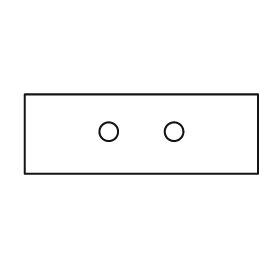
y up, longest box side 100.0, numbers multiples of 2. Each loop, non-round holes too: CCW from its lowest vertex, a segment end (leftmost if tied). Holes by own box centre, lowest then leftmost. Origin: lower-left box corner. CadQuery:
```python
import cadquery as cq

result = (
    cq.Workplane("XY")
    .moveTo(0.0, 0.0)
    .lineTo(100.0, 0.0)
    .lineTo(100.0, 34.0)
    .lineTo(0.0, 34.0)
    .close()
    .moveTo(36.0, 18.0)
    .circle(4.0)
    .moveTo(64.0, 18.0)
    .circle(4.0)
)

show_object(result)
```